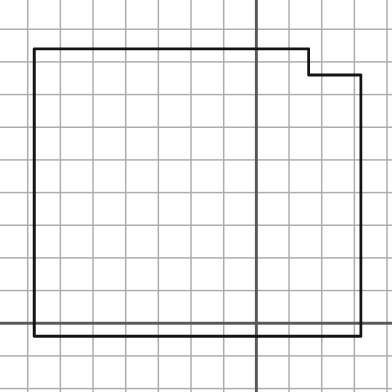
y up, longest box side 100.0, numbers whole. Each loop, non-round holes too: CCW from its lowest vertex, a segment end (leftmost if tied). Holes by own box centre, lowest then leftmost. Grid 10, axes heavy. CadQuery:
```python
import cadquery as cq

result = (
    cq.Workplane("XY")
    .moveTo(-68.0, -4.0)
    .lineTo(32.0, -4.0)
    .lineTo(32.0, 76.0)
    .lineTo(16.0, 76.0)
    .lineTo(16.0, 84.0)
    .lineTo(-68.0, 84.0)
    .close()
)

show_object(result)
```